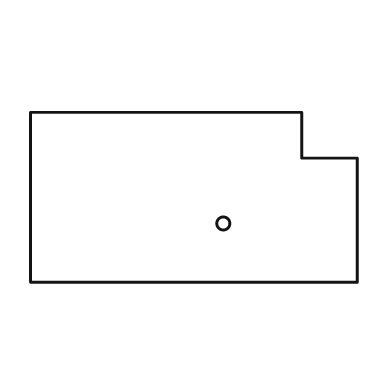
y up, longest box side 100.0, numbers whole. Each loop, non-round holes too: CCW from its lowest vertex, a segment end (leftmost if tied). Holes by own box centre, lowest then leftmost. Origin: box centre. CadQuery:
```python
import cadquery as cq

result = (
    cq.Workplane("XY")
    .moveTo(-50.0, -26.0)
    .lineTo(50.0, -26.0)
    .lineTo(50.0, 12.0)
    .lineTo(33.0, 12.0)
    .lineTo(33.0, 26.0)
    .lineTo(-50.0, 26.0)
    .close()
    .moveTo(9.0, -8.0)
    .circle(2.0)
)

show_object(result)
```